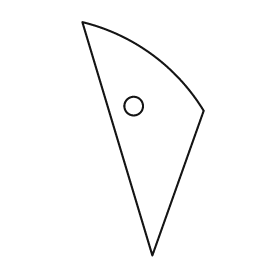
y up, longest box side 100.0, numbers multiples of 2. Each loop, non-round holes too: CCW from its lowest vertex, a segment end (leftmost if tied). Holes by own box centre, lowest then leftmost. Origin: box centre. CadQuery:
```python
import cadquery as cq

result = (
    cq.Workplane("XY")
    .moveTo(4.0, -50.0)
    .lineTo(26.0, 12.0)
    .threePointArc((4.0, 36.0), (-26.0, 50.0))
    .close()
    .moveTo(-4.0, 14.0)
    .circle(4.0)
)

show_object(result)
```